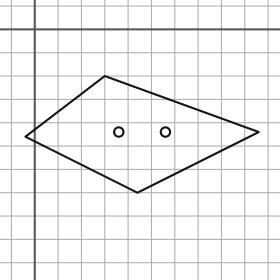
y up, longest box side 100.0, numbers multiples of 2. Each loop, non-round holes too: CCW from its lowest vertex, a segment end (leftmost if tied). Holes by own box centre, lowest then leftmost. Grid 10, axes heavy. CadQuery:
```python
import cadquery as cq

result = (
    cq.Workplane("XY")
    .moveTo(44.0, -70.0)
    .lineTo(96.0, -44.0)
    .lineTo(30.0, -20.0)
    .lineTo(-4.0, -46.0)
    .close()
    .moveTo(36.0, -44.0)
    .circle(2.0)
    .moveTo(56.0, -44.0)
    .circle(2.0)
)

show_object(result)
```